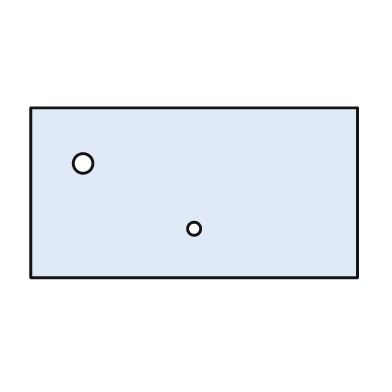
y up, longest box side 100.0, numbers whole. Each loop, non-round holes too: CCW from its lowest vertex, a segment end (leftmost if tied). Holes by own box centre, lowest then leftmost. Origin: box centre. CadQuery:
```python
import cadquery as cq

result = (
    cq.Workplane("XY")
    .moveTo(-50.0, -26.0)
    .lineTo(50.0, -26.0)
    .lineTo(50.0, 26.0)
    .lineTo(-50.0, 26.0)
    .close()
    .moveTo(0.0, -11.0)
    .circle(2.0)
    .moveTo(-34.0, 9.0)
    .circle(3.0)
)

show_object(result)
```